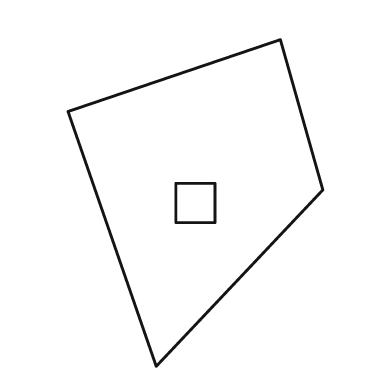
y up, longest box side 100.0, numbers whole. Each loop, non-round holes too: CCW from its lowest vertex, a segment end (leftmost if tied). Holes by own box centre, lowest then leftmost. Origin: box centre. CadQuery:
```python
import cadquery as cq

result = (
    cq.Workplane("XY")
    .moveTo(-12.0, -50.0)
    .lineTo(39.0, 4.0)
    .lineTo(26.0, 50.0)
    .lineTo(-39.0, 28.0)
    .close()
    .moveTo(-6.0, -6.0)
    .lineTo(6.0, -6.0)
    .lineTo(6.0, 6.0)
    .lineTo(-6.0, 6.0)
    .close()
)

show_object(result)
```